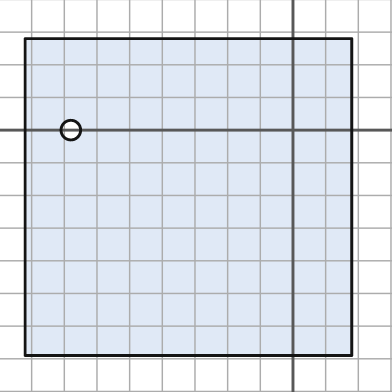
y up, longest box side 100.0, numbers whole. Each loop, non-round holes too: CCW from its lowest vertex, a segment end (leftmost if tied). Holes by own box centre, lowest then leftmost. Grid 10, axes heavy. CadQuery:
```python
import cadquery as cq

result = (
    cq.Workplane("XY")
    .moveTo(-82.0, -69.0)
    .lineTo(18.0, -69.0)
    .lineTo(18.0, 28.0)
    .lineTo(-82.0, 28.0)
    .close()
    .moveTo(-68.0, 0.0)
    .circle(3.0)
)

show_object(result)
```